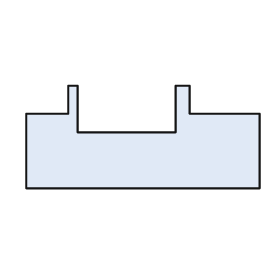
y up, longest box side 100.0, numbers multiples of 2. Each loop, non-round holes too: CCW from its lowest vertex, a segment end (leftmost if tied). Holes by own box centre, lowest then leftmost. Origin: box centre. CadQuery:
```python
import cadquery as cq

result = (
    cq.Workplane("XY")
    .moveTo(-50.0, -22.0)
    .lineTo(50.0, -22.0)
    .lineTo(50.0, 10.0)
    .lineTo(20.0, 10.0)
    .lineTo(20.0, 22.0)
    .lineTo(14.0, 22.0)
    .lineTo(14.0, 2.0)
    .lineTo(-28.0, 2.0)
    .lineTo(-28.0, 22.0)
    .lineTo(-32.0, 22.0)
    .lineTo(-32.0, 10.0)
    .lineTo(-50.0, 10.0)
    .close()
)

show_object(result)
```